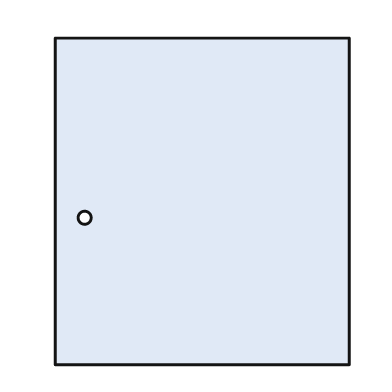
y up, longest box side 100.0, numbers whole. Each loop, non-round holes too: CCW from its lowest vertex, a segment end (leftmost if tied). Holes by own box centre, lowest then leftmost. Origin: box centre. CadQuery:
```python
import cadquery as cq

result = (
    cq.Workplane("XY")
    .moveTo(-45.0, -50.0)
    .lineTo(45.0, -50.0)
    .lineTo(45.0, 50.0)
    .lineTo(-45.0, 50.0)
    .close()
    .moveTo(-36.0, -5.0)
    .circle(2.0)
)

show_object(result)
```